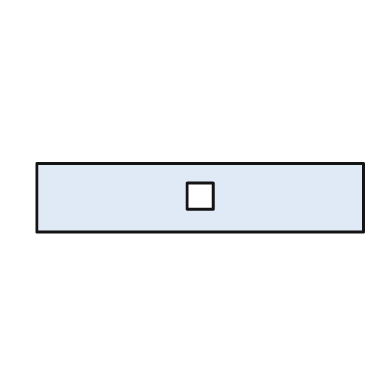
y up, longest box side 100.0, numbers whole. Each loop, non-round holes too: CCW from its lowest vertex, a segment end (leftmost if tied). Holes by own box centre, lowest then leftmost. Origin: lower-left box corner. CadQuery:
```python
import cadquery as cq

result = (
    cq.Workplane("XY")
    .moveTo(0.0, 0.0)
    .lineTo(100.0, 0.0)
    .lineTo(100.0, 21.0)
    .lineTo(0.0, 21.0)
    .close()
    .moveTo(46.0, 7.0)
    .lineTo(54.0, 7.0)
    .lineTo(54.0, 15.0)
    .lineTo(46.0, 15.0)
    .close()
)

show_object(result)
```